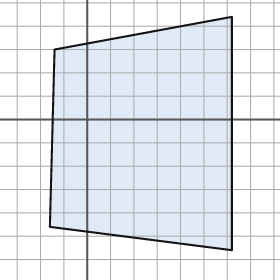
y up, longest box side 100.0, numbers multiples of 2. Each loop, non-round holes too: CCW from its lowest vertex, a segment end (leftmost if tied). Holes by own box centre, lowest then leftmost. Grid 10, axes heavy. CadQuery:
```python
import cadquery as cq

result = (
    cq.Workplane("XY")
    .moveTo(62.0, -56.0)
    .lineTo(62.0, 44.0)
    .lineTo(-14.0, 30.0)
    .lineTo(-16.0, -46.0)
    .close()
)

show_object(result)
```